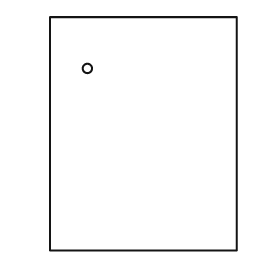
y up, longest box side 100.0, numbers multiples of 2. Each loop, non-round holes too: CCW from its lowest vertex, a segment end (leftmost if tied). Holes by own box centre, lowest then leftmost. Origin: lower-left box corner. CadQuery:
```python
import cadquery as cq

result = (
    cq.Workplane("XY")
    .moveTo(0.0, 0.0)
    .lineTo(80.0, 0.0)
    .lineTo(80.0, 100.0)
    .lineTo(0.0, 100.0)
    .close()
    .moveTo(16.0, 78.0)
    .circle(2.0)
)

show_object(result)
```